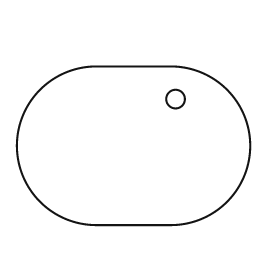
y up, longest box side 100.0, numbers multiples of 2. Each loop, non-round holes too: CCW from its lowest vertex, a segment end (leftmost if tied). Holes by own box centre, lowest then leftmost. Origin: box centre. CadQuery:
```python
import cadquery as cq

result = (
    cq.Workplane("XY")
    .moveTo(-16.0, -34.0)
    .lineTo(16.0, -34.0)
    .threePointArc((50.0, 0.0), (16.0, 34.0))
    .lineTo(-16.0, 34.0)
    .threePointArc((-50.0, 0.0), (-16.0, -34.0))
    .close()
    .moveTo(18.0, 20.0)
    .circle(4.0)
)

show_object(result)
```